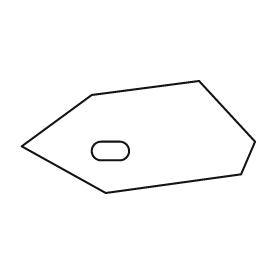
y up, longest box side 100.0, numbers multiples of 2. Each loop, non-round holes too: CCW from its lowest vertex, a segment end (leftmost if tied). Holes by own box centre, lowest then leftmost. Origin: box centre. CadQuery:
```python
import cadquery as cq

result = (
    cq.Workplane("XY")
    .moveTo(-14.0, -24.0)
    .lineTo(44.0, -16.0)
    .lineTo(50.0, -2.0)
    .lineTo(26.0, 24.0)
    .lineTo(-20.0, 18.0)
    .lineTo(-50.0, -4.0)
    .close()
    .moveTo(-16.0, -10.0)
    .lineTo(-8.0, -10.0)
    .threePointArc((-4.0, -6.0), (-8.0, -2.0))
    .lineTo(-16.0, -2.0)
    .threePointArc((-20.0, -6.0), (-16.0, -10.0))
    .close()
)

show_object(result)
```